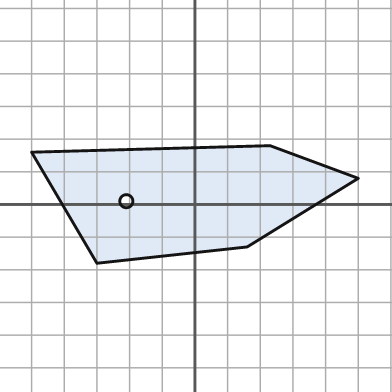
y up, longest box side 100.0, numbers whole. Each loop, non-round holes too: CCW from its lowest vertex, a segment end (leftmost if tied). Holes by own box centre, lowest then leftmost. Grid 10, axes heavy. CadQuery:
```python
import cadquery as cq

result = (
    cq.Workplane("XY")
    .moveTo(-30.0, -18.0)
    .lineTo(16.0, -13.0)
    .lineTo(50.0, 8.0)
    .lineTo(23.0, 18.0)
    .lineTo(-50.0, 16.0)
    .close()
    .moveTo(-21.0, 1.0)
    .circle(2.0)
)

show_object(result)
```